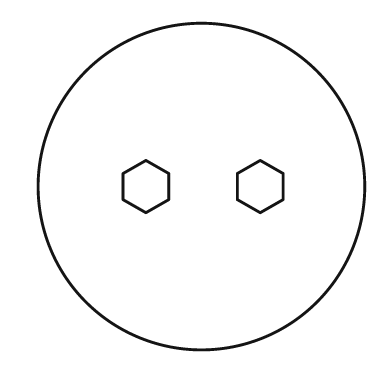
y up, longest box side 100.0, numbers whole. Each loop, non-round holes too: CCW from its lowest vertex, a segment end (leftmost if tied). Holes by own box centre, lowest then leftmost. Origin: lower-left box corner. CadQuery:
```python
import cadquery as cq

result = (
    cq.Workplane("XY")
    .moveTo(50.0, 50.0)
    .circle(50.0)
    .moveTo(33.0, 42.0)
    .lineTo(40.0, 46.0)
    .lineTo(40.0, 54.0)
    .lineTo(33.0, 58.0)
    .lineTo(26.0, 54.0)
    .lineTo(26.0, 46.0)
    .close()
    .moveTo(68.0, 42.0)
    .lineTo(75.0, 46.0)
    .lineTo(75.0, 54.0)
    .lineTo(68.0, 58.0)
    .lineTo(61.0, 54.0)
    .lineTo(61.0, 46.0)
    .close()
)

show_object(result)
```